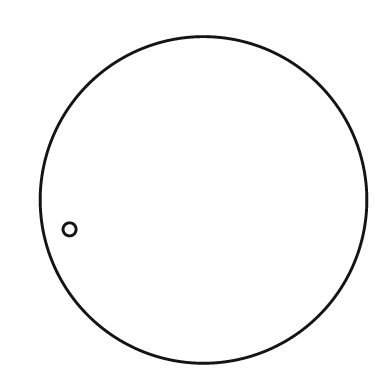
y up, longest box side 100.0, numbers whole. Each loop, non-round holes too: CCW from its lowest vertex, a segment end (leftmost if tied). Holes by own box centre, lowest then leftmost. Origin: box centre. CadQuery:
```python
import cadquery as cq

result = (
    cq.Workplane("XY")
    .moveTo(0.0, 0.0)
    .circle(50.0)
    .moveTo(-41.0, -9.0)
    .circle(2.0)
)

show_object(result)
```